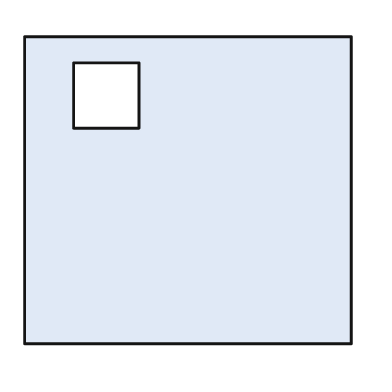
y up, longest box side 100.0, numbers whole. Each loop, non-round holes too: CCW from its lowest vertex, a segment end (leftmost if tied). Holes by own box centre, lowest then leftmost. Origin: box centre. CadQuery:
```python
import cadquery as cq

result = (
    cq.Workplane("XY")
    .moveTo(-50.0, -47.0)
    .lineTo(50.0, -47.0)
    .lineTo(50.0, 47.0)
    .lineTo(-50.0, 47.0)
    .close()
    .moveTo(-35.0, 19.0)
    .lineTo(-15.0, 19.0)
    .lineTo(-15.0, 39.0)
    .lineTo(-35.0, 39.0)
    .close()
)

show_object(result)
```